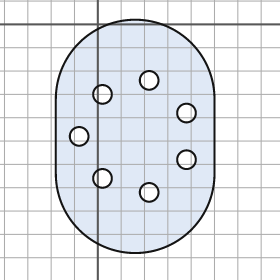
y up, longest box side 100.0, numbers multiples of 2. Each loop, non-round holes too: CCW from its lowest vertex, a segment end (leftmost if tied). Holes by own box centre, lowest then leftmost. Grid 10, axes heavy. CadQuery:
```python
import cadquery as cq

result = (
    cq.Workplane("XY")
    .moveTo(-18.0, -64.0)
    .threePointArc((16.0, -98.0), (50.0, -64.0))
    .lineTo(50.0, -32.0)
    .threePointArc((16.0, 2.0), (-18.0, -32.0))
    .close()
    .moveTo(22.0, -72.0)
    .circle(4.0)
    .moveTo(2.0, -66.0)
    .circle(4.0)
    .moveTo(38.0, -58.0)
    .circle(4.0)
    .moveTo(-8.0, -48.0)
    .circle(4.0)
    .moveTo(38.0, -38.0)
    .circle(4.0)
    .moveTo(2.0, -30.0)
    .circle(4.0)
    .moveTo(22.0, -24.0)
    .circle(4.0)
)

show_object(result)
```